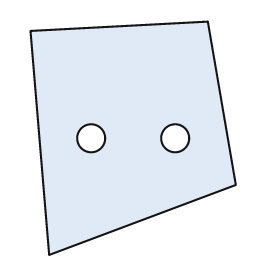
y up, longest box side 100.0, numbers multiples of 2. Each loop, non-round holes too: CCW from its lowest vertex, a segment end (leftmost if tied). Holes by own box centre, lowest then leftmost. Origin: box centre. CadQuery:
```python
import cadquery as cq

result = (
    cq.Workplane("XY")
    .moveTo(-36.0, -50.0)
    .lineTo(44.0, -20.0)
    .lineTo(32.0, 50.0)
    .lineTo(-44.0, 46.0)
    .close()
    .moveTo(-18.0, 0.0)
    .circle(6.0)
    .moveTo(18.0, 0.0)
    .circle(6.0)
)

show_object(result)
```